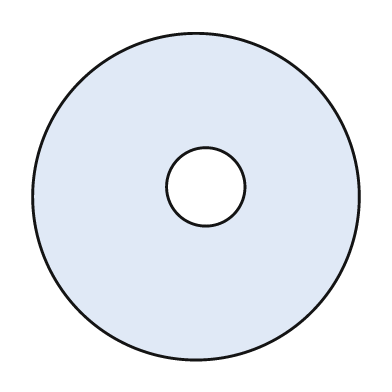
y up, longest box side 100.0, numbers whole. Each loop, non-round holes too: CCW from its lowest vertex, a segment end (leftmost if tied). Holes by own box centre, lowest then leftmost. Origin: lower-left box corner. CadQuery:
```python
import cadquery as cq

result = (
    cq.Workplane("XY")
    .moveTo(50.0, 50.0)
    .circle(50.0)
    .moveTo(53.0, 53.0)
    .circle(12.0)
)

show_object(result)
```